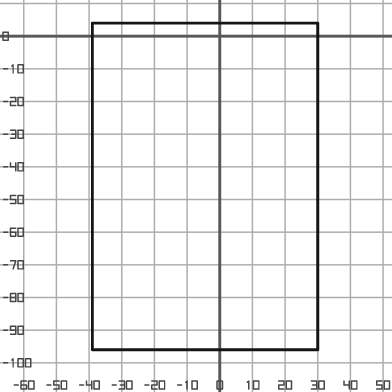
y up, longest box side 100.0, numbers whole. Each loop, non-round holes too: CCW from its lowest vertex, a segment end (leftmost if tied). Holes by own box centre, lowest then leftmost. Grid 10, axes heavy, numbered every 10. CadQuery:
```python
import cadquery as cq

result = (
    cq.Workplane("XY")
    .moveTo(-39.0, -96.0)
    .lineTo(30.0, -96.0)
    .lineTo(30.0, 4.0)
    .lineTo(-39.0, 4.0)
    .close()
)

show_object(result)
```